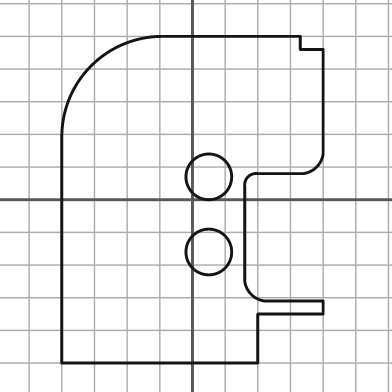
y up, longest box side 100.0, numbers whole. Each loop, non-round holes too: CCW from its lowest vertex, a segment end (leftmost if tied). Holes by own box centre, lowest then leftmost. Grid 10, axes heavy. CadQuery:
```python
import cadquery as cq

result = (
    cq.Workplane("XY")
    .moveTo(-40.0, -50.0)
    .lineTo(20.0, -50.0)
    .lineTo(20.0, -35.0)
    .lineTo(40.0, -35.0)
    .lineTo(40.0, -31.0)
    .lineTo(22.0, -31.0)
    .threePointArc((18.0, -29.0), (16.0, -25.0))
    .lineTo(16.0, 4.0)
    .threePointArc((17.0, 7.0), (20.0, 8.0))
    .lineTo(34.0, 8.0)
    .threePointArc((38.0, 10.0), (40.0, 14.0))
    .lineTo(40.0, 46.0)
    .lineTo(33.0, 46.0)
    .lineTo(33.0, 50.0)
    .lineTo(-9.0, 50.0)
    .threePointArc((-31.0, 41.0), (-40.0, 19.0))
    .close()
    .moveTo(5.0, -16.0)
    .circle(7.0)
    .moveTo(5.0, 7.0)
    .circle(7.0)
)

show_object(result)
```